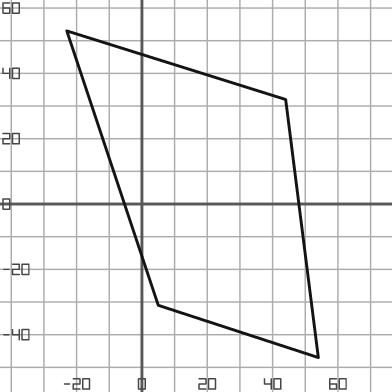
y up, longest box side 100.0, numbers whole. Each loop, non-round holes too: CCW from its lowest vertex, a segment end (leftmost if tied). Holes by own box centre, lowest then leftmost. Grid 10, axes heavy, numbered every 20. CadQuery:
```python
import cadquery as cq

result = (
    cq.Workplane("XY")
    .moveTo(54.0, -47.0)
    .lineTo(44.0, 32.0)
    .lineTo(-23.0, 53.0)
    .lineTo(5.0, -31.0)
    .close()
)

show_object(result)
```